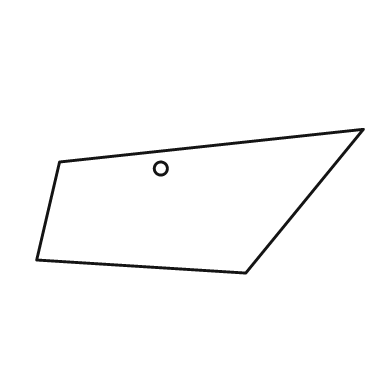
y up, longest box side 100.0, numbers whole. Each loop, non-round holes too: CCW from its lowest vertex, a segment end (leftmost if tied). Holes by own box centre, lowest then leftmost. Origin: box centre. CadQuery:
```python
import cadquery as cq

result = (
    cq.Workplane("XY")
    .moveTo(14.0, -22.0)
    .lineTo(50.0, 22.0)
    .lineTo(-43.0, 12.0)
    .lineTo(-50.0, -18.0)
    .close()
    .moveTo(-12.0, 10.0)
    .circle(2.0)
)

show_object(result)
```